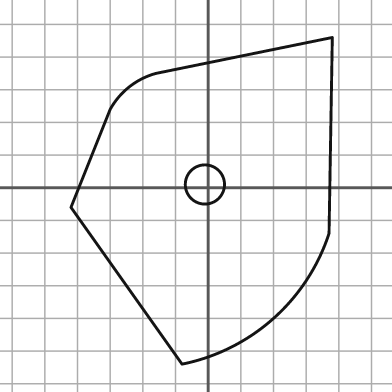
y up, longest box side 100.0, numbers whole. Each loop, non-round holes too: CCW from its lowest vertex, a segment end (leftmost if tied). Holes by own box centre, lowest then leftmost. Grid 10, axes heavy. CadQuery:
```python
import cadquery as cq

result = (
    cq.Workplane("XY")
    .moveTo(-8.0, -54.0)
    .threePointArc((20.0, -40.0), (37.0, -14.0))
    .lineTo(38.0, 46.0)
    .lineTo(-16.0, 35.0)
    .threePointArc((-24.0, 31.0), (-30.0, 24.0))
    .lineTo(-42.0, -6.0)
    .close()
    .moveTo(-1.0, 1.0)
    .circle(6.0)
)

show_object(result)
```